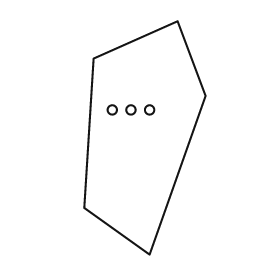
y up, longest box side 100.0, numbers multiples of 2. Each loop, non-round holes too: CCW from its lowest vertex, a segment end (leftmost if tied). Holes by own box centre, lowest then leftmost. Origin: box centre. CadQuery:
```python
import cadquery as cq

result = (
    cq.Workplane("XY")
    .moveTo(2.0, -50.0)
    .lineTo(26.0, 18.0)
    .lineTo(14.0, 50.0)
    .lineTo(-22.0, 34.0)
    .lineTo(-26.0, -30.0)
    .close()
    .moveTo(-14.0, 12.0)
    .circle(2.0)
    .moveTo(-6.0, 12.0)
    .circle(2.0)
    .moveTo(2.0, 12.0)
    .circle(2.0)
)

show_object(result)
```